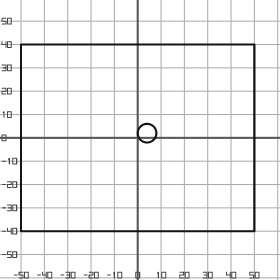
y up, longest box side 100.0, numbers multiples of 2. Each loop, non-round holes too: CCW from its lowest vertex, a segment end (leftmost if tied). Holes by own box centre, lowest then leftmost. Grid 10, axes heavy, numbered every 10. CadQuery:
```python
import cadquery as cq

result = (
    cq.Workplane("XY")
    .moveTo(-50.0, -40.0)
    .lineTo(50.0, -40.0)
    .lineTo(50.0, 40.0)
    .lineTo(-50.0, 40.0)
    .close()
    .moveTo(4.0, 2.0)
    .circle(4.0)
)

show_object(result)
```